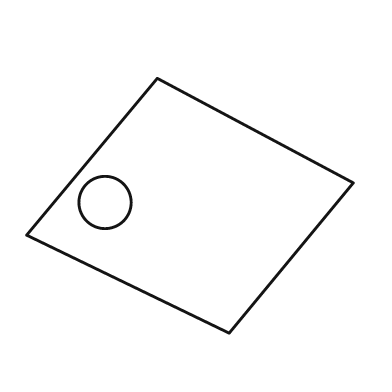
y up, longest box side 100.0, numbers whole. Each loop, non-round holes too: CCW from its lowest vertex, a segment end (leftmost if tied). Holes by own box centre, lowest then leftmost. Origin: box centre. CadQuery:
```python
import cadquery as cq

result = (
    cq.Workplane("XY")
    .moveTo(12.0, -39.0)
    .lineTo(50.0, 7.0)
    .lineTo(-10.0, 39.0)
    .lineTo(-50.0, -9.0)
    .close()
    .moveTo(-26.0, 1.0)
    .circle(8.0)
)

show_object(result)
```